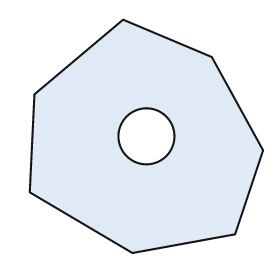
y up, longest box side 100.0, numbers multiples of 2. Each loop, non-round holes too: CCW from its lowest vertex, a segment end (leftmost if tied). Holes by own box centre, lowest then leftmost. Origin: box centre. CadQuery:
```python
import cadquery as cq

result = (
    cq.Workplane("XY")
    .moveTo(-6.0, -50.0)
    .lineTo(38.0, -42.0)
    .lineTo(50.0, -6.0)
    .lineTo(28.0, 34.0)
    .lineTo(-10.0, 50.0)
    .lineTo(-48.0, 18.0)
    .lineTo(-50.0, -24.0)
    .close()
    .moveTo(0.0, 0.0)
    .circle(12.0)
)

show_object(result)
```